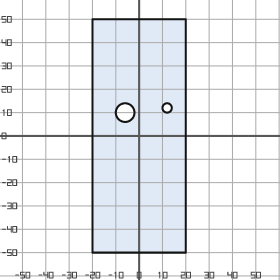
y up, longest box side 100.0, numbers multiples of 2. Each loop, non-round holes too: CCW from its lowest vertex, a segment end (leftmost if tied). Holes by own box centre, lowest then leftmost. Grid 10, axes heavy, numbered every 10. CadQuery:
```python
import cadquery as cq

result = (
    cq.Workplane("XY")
    .moveTo(-20.0, -50.0)
    .lineTo(20.0, -50.0)
    .lineTo(20.0, 50.0)
    .lineTo(-20.0, 50.0)
    .close()
    .moveTo(-6.0, 10.0)
    .circle(4.0)
    .moveTo(12.0, 12.0)
    .circle(2.0)
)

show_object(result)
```